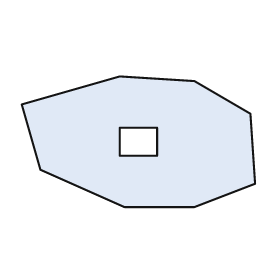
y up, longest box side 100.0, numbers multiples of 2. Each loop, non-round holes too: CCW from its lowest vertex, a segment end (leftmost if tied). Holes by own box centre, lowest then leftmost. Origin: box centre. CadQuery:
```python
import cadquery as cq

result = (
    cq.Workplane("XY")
    .moveTo(-6.0, -28.0)
    .lineTo(24.0, -28.0)
    .lineTo(50.0, -18.0)
    .lineTo(48.0, 12.0)
    .lineTo(24.0, 26.0)
    .lineTo(-8.0, 28.0)
    .lineTo(-50.0, 16.0)
    .lineTo(-42.0, -12.0)
    .close()
    .moveTo(-8.0, -6.0)
    .lineTo(8.0, -6.0)
    .lineTo(8.0, 6.0)
    .lineTo(-8.0, 6.0)
    .close()
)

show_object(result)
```